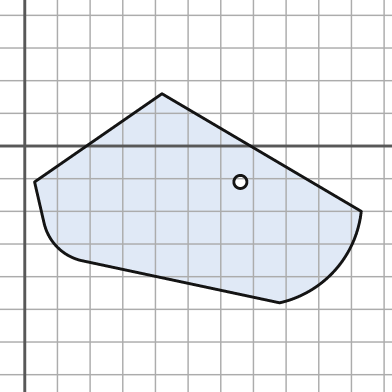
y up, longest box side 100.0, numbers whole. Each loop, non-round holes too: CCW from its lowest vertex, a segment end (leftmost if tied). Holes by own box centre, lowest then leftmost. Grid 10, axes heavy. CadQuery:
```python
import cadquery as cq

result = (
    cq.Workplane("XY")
    .moveTo(78.0, -48.0)
    .threePointArc((95.0, -38.0), (103.0, -20.0))
    .lineTo(42.0, 16.0)
    .lineTo(3.0, -11.0)
    .lineTo(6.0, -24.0)
    .threePointArc((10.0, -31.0), (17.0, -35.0))
    .close()
    .moveTo(66.0, -11.0)
    .circle(2.0)
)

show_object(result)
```